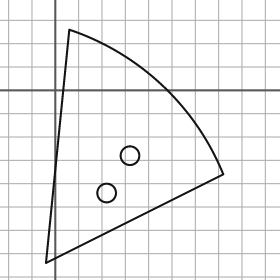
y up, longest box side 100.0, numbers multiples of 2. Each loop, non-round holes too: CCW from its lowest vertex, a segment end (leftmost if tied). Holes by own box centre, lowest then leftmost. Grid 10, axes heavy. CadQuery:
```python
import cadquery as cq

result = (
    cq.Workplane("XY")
    .moveTo(-4.0, -74.0)
    .lineTo(72.0, -36.0)
    .threePointArc((46.0, 2.0), (6.0, 26.0))
    .close()
    .moveTo(22.0, -44.0)
    .circle(4.0)
    .moveTo(32.0, -28.0)
    .circle(4.0)
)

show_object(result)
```